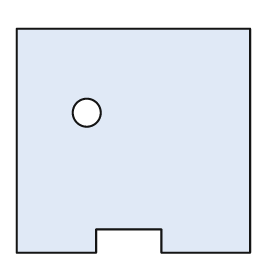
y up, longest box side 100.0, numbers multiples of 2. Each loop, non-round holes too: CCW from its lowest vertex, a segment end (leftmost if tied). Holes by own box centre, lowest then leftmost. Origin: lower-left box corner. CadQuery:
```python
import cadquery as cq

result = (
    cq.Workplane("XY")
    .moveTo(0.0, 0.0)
    .lineTo(34.0, 0.0)
    .lineTo(34.0, 10.0)
    .lineTo(62.0, 10.0)
    .lineTo(62.0, 0.0)
    .lineTo(100.0, 0.0)
    .lineTo(100.0, 96.0)
    .lineTo(0.0, 96.0)
    .close()
    .moveTo(30.0, 60.0)
    .circle(6.0)
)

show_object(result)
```